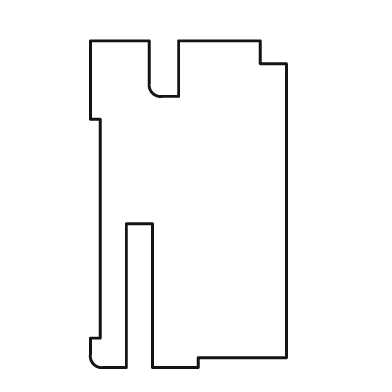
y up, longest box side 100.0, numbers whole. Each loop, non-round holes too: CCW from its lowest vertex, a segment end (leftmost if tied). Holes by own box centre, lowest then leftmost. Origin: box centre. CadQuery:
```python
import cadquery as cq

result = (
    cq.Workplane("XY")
    .moveTo(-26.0, -50.0)
    .lineTo(-19.0, -50.0)
    .lineTo(-19.0, -6.0)
    .lineTo(-11.0, -6.0)
    .lineTo(-11.0, -50.0)
    .lineTo(3.0, -50.0)
    .lineTo(3.0, -47.0)
    .lineTo(30.0, -47.0)
    .lineTo(30.0, 43.0)
    .lineTo(22.0, 43.0)
    .lineTo(22.0, 50.0)
    .lineTo(-3.0, 50.0)
    .lineTo(-3.0, 33.0)
    .lineTo(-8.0, 33.0)
    .threePointArc((-11.0, 34.0), (-12.0, 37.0))
    .lineTo(-12.0, 50.0)
    .lineTo(-30.0, 50.0)
    .lineTo(-30.0, 26.0)
    .lineTo(-27.0, 26.0)
    .lineTo(-27.0, -41.0)
    .lineTo(-30.0, -41.0)
    .lineTo(-30.0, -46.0)
    .threePointArc((-29.0, -49.0), (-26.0, -50.0))
    .close()
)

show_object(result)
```